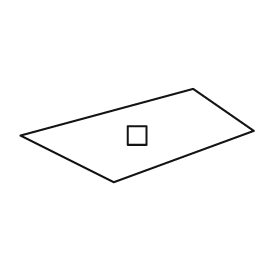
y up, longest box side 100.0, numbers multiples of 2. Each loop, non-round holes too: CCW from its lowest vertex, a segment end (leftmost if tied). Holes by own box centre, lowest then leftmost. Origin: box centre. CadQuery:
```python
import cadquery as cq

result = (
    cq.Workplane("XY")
    .moveTo(-10.0, -20.0)
    .lineTo(50.0, 2.0)
    .lineTo(24.0, 20.0)
    .lineTo(-50.0, 0.0)
    .close()
    .moveTo(-4.0, -4.0)
    .lineTo(4.0, -4.0)
    .lineTo(4.0, 4.0)
    .lineTo(-4.0, 4.0)
    .close()
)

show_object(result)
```